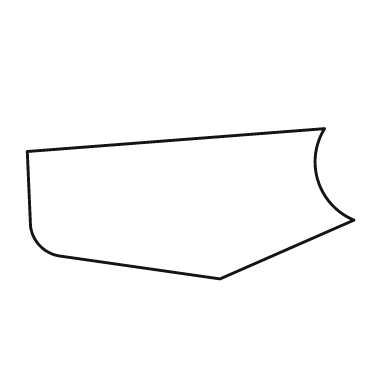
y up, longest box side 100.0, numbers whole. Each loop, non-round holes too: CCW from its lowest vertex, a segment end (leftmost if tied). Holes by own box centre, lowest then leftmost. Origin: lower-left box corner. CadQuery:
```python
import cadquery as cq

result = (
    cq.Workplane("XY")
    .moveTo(59.0, 0.0)
    .lineTo(100.0, 18.0)
    .threePointArc((89.0, 30.0), (91.0, 46.0))
    .lineTo(0.0, 39.0)
    .lineTo(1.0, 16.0)
    .threePointArc((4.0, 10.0), (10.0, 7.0))
    .close()
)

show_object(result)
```